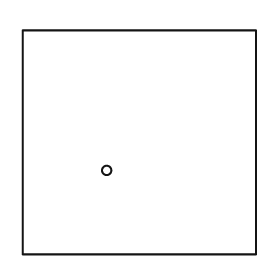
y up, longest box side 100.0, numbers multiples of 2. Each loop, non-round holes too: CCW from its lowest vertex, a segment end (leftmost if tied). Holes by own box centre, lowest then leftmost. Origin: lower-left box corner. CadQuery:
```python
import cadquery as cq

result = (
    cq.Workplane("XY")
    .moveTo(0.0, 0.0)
    .lineTo(100.0, 0.0)
    .lineTo(100.0, 96.0)
    .lineTo(0.0, 96.0)
    .close()
    .moveTo(36.0, 36.0)
    .circle(2.0)
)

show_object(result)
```